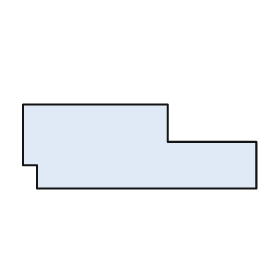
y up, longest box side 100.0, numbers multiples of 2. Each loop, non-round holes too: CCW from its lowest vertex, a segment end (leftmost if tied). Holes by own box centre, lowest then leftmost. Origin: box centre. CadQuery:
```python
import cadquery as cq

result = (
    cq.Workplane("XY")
    .moveTo(-44.0, -18.0)
    .lineTo(50.0, -18.0)
    .lineTo(50.0, 2.0)
    .lineTo(12.0, 2.0)
    .lineTo(12.0, 18.0)
    .lineTo(-50.0, 18.0)
    .lineTo(-50.0, -8.0)
    .lineTo(-44.0, -8.0)
    .close()
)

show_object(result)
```